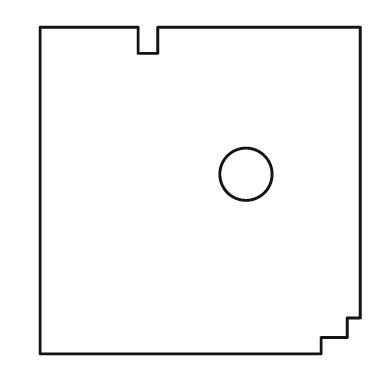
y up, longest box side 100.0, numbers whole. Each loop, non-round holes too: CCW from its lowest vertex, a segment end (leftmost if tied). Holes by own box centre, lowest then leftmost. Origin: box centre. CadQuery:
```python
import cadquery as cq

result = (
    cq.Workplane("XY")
    .moveTo(-49.0, -50.0)
    .lineTo(37.0, -50.0)
    .lineTo(37.0, -45.0)
    .lineTo(45.0, -45.0)
    .lineTo(45.0, -39.0)
    .lineTo(49.0, -39.0)
    .lineTo(49.0, 50.0)
    .lineTo(-13.0, 50.0)
    .lineTo(-13.0, 42.0)
    .lineTo(-19.0, 42.0)
    .lineTo(-19.0, 50.0)
    .lineTo(-49.0, 50.0)
    .close()
    .moveTo(14.0, 5.0)
    .circle(8.0)
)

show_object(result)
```